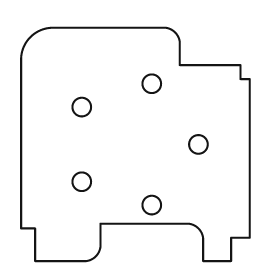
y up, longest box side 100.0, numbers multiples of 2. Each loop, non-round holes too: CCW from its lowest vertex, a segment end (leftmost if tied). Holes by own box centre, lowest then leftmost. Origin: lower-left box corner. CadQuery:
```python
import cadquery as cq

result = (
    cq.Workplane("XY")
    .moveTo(6.0, 0.0)
    .lineTo(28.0, 0.0)
    .threePointArc((32.0, 2.0), (34.0, 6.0))
    .lineTo(34.0, 16.0)
    .lineTo(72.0, 16.0)
    .threePointArc((76.0, 14.0), (78.0, 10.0))
    .lineTo(78.0, 0.0)
    .lineTo(90.0, 0.0)
    .lineTo(90.0, 10.0)
    .lineTo(98.0, 10.0)
    .lineTo(98.0, 78.0)
    .lineTo(94.0, 78.0)
    .lineTo(94.0, 84.0)
    .lineTo(68.0, 84.0)
    .lineTo(68.0, 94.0)
    .threePointArc((66.0, 98.0), (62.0, 100.0))
    .lineTo(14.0, 100.0)
    .threePointArc((4.0, 96.0), (0.0, 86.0))
    .lineTo(0.0, 14.0)
    .lineTo(6.0, 14.0)
    .close()
    .moveTo(56.0, 24.0)
    .circle(4.0)
    .moveTo(26.0, 34.0)
    .circle(4.0)
    .moveTo(76.0, 50.0)
    .circle(4.0)
    .moveTo(26.0, 66.0)
    .circle(4.0)
    .moveTo(56.0, 76.0)
    .circle(4.0)
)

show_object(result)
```